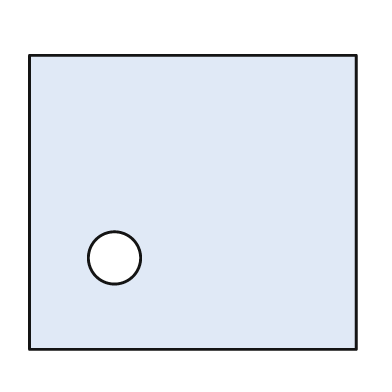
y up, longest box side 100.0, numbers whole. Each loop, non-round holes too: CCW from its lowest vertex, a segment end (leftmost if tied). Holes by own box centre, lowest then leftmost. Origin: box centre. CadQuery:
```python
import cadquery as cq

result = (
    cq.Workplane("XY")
    .moveTo(-50.0, -45.0)
    .lineTo(50.0, -45.0)
    .lineTo(50.0, 45.0)
    .lineTo(-50.0, 45.0)
    .close()
    .moveTo(-24.0, -17.0)
    .circle(8.0)
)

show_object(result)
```